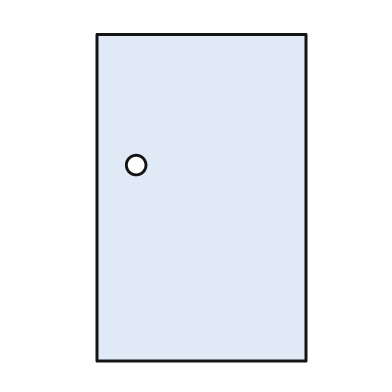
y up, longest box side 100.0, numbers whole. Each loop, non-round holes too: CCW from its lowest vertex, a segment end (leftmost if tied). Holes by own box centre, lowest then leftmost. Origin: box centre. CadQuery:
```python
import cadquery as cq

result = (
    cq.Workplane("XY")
    .moveTo(-32.0, -50.0)
    .lineTo(32.0, -50.0)
    .lineTo(32.0, 50.0)
    .lineTo(-32.0, 50.0)
    .close()
    .moveTo(-20.0, 10.0)
    .circle(3.0)
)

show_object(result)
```